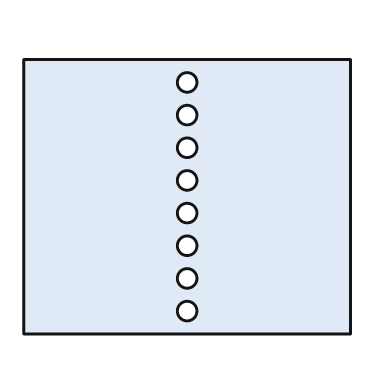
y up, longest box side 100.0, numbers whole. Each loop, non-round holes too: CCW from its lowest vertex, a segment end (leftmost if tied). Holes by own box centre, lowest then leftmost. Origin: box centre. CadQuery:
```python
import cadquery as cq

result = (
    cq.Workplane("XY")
    .moveTo(-50.0, -42.0)
    .lineTo(50.0, -42.0)
    .lineTo(50.0, 42.0)
    .lineTo(-50.0, 42.0)
    .close()
    .moveTo(0.0, -35.0)
    .circle(3.0)
    .moveTo(0.0, -25.0)
    .circle(3.0)
    .moveTo(0.0, -15.0)
    .circle(3.0)
    .moveTo(0.0, -5.0)
    .circle(3.0)
    .moveTo(0.0, 5.0)
    .circle(3.0)
    .moveTo(0.0, 15.0)
    .circle(3.0)
    .moveTo(0.0, 25.0)
    .circle(3.0)
    .moveTo(0.0, 35.0)
    .circle(3.0)
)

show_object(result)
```